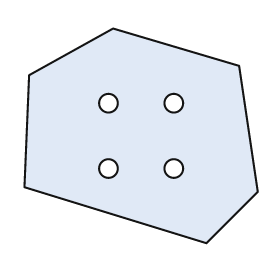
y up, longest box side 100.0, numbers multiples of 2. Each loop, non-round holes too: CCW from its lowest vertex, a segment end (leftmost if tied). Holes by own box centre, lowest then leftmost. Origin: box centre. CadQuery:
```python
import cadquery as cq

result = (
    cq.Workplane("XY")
    .moveTo(28.0, -46.0)
    .lineTo(50.0, -24.0)
    .lineTo(42.0, 30.0)
    .lineTo(-12.0, 46.0)
    .lineTo(-48.0, 26.0)
    .lineTo(-50.0, -22.0)
    .close()
    .moveTo(-14.0, -14.0)
    .circle(4.0)
    .moveTo(14.0, -14.0)
    .circle(4.0)
    .moveTo(-14.0, 14.0)
    .circle(4.0)
    .moveTo(14.0, 14.0)
    .circle(4.0)
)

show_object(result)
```